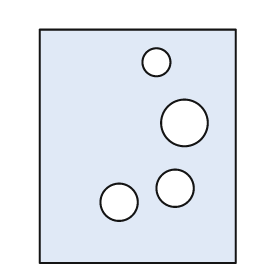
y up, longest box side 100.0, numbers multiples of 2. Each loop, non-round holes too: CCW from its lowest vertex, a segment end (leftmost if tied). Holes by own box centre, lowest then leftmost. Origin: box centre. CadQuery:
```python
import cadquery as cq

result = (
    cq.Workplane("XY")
    .moveTo(-42.0, -50.0)
    .lineTo(42.0, -50.0)
    .lineTo(42.0, 50.0)
    .lineTo(-42.0, 50.0)
    .close()
    .moveTo(-8.0, -24.0)
    .circle(8.0)
    .moveTo(16.0, -18.0)
    .circle(8.0)
    .moveTo(20.0, 10.0)
    .circle(10.0)
    .moveTo(8.0, 36.0)
    .circle(6.0)
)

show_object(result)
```